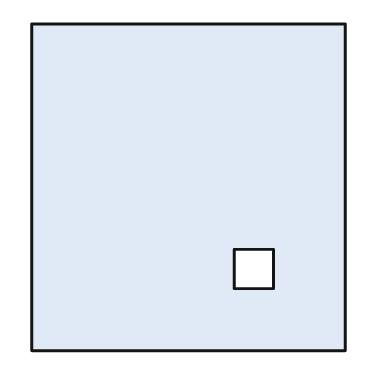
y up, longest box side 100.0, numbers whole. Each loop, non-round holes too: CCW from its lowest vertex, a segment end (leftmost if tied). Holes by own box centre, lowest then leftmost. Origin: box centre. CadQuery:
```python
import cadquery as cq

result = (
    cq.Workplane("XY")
    .moveTo(-48.0, -50.0)
    .lineTo(48.0, -50.0)
    .lineTo(48.0, 50.0)
    .lineTo(-48.0, 50.0)
    .close()
    .moveTo(14.0, -31.0)
    .lineTo(26.0, -31.0)
    .lineTo(26.0, -19.0)
    .lineTo(14.0, -19.0)
    .close()
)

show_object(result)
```